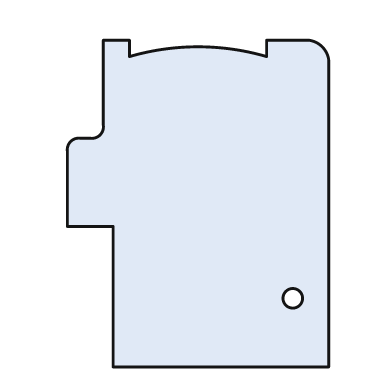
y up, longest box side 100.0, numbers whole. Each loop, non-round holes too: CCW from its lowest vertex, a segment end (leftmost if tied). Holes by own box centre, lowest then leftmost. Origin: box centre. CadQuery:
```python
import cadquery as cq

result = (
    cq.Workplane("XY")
    .moveTo(-26.0, -50.0)
    .lineTo(40.0, -50.0)
    .lineTo(40.0, 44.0)
    .threePointArc((38.0, 48.0), (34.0, 50.0))
    .lineTo(21.0, 50.0)
    .lineTo(21.0, 45.0)
    .threePointArc((0.0, 48.0), (-21.0, 45.0))
    .lineTo(-21.0, 50.0)
    .lineTo(-29.0, 50.0)
    .lineTo(-29.0, 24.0)
    .threePointArc((-30.0, 21.0), (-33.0, 20.0))
    .lineTo(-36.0, 20.0)
    .threePointArc((-39.0, 19.0), (-40.0, 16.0))
    .lineTo(-40.0, -7.0)
    .lineTo(-26.0, -7.0)
    .close()
    .moveTo(29.0, -29.0)
    .circle(3.0)
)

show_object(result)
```